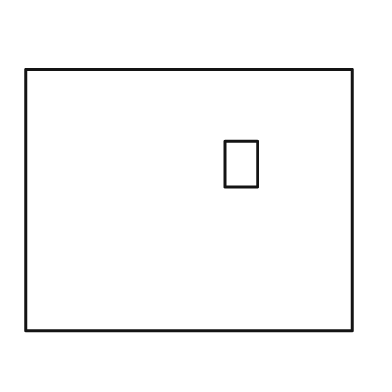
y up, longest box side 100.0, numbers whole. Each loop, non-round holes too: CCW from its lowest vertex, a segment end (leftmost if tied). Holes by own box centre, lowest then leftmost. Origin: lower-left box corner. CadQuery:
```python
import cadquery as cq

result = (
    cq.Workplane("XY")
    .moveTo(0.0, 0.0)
    .lineTo(100.0, 0.0)
    .lineTo(100.0, 80.0)
    .lineTo(0.0, 80.0)
    .close()
    .moveTo(61.0, 44.0)
    .lineTo(71.0, 44.0)
    .lineTo(71.0, 58.0)
    .lineTo(61.0, 58.0)
    .close()
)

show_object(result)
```